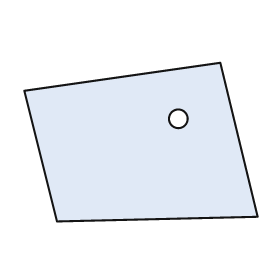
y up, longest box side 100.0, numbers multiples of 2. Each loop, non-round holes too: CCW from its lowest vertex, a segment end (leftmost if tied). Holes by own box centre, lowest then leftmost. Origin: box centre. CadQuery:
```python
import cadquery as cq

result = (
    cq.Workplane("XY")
    .moveTo(-36.0, -34.0)
    .lineTo(50.0, -32.0)
    .lineTo(34.0, 34.0)
    .lineTo(-50.0, 22.0)
    .close()
    .moveTo(16.0, 10.0)
    .circle(4.0)
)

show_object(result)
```